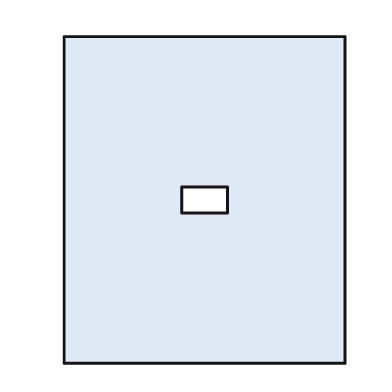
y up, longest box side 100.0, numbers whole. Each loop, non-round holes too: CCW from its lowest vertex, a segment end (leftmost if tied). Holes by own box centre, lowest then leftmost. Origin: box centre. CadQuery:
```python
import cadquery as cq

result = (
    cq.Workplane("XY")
    .moveTo(-43.0, -50.0)
    .lineTo(43.0, -50.0)
    .lineTo(43.0, 50.0)
    .lineTo(-43.0, 50.0)
    .close()
    .moveTo(-7.0, -4.0)
    .lineTo(7.0, -4.0)
    .lineTo(7.0, 4.0)
    .lineTo(-7.0, 4.0)
    .close()
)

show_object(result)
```